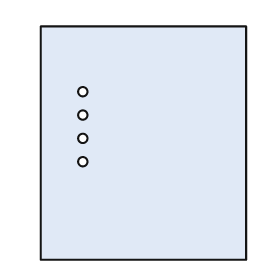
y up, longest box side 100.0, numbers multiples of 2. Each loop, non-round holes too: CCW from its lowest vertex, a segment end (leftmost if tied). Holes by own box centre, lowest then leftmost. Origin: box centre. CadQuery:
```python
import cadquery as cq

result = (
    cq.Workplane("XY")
    .moveTo(-44.0, -50.0)
    .lineTo(44.0, -50.0)
    .lineTo(44.0, 50.0)
    .lineTo(-44.0, 50.0)
    .close()
    .moveTo(-26.0, -8.0)
    .circle(2.0)
    .moveTo(-26.0, 2.0)
    .circle(2.0)
    .moveTo(-26.0, 12.0)
    .circle(2.0)
    .moveTo(-26.0, 22.0)
    .circle(2.0)
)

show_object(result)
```